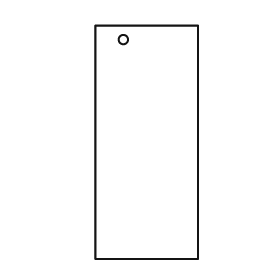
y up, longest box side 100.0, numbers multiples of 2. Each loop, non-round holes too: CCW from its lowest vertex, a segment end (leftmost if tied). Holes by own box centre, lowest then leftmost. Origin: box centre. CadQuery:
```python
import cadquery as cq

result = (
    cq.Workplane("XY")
    .moveTo(-22.0, -50.0)
    .lineTo(22.0, -50.0)
    .lineTo(22.0, 50.0)
    .lineTo(-22.0, 50.0)
    .close()
    .moveTo(-10.0, 44.0)
    .circle(2.0)
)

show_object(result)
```